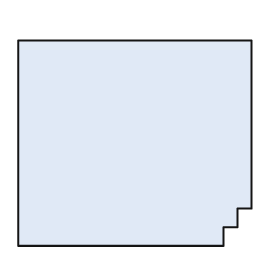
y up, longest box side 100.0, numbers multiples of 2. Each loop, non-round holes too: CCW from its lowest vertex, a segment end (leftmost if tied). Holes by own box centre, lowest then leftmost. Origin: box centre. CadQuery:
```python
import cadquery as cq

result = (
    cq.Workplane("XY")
    .moveTo(-50.0, -44.0)
    .lineTo(38.0, -44.0)
    .lineTo(38.0, -36.0)
    .lineTo(44.0, -36.0)
    .lineTo(44.0, -28.0)
    .lineTo(50.0, -28.0)
    .lineTo(50.0, 44.0)
    .lineTo(-50.0, 44.0)
    .close()
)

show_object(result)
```